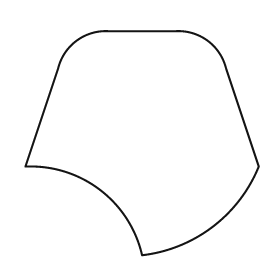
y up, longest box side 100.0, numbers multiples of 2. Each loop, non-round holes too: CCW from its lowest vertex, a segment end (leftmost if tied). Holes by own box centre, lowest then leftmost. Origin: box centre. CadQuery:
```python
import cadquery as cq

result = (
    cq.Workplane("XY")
    .moveTo(0.0, -48.0)
    .threePointArc((30.0, -36.0), (50.0, -10.0))
    .lineTo(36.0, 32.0)
    .threePointArc((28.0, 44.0), (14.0, 48.0))
    .lineTo(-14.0, 48.0)
    .threePointArc((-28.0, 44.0), (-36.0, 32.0))
    .lineTo(-50.0, -10.0)
    .threePointArc((-18.0, -20.0), (0.0, -48.0))
    .close()
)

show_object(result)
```